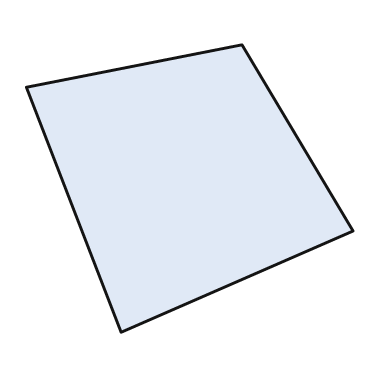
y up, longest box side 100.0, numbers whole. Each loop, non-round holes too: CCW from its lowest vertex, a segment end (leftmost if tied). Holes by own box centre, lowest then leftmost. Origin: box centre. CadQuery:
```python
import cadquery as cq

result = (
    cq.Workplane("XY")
    .moveTo(-21.0, -44.0)
    .lineTo(50.0, -13.0)
    .lineTo(16.0, 44.0)
    .lineTo(-50.0, 31.0)
    .close()
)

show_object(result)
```